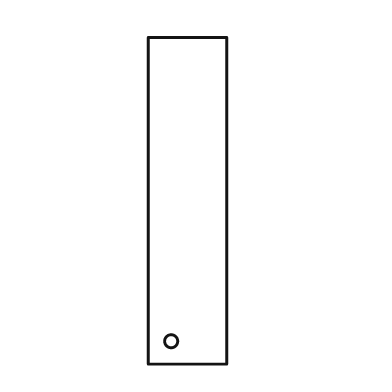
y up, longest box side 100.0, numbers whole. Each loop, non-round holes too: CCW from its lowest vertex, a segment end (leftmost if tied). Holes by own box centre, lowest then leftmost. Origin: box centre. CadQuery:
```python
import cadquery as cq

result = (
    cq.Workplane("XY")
    .moveTo(-12.0, -50.0)
    .lineTo(12.0, -50.0)
    .lineTo(12.0, 50.0)
    .lineTo(-12.0, 50.0)
    .close()
    .moveTo(-5.0, -43.0)
    .circle(2.0)
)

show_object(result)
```